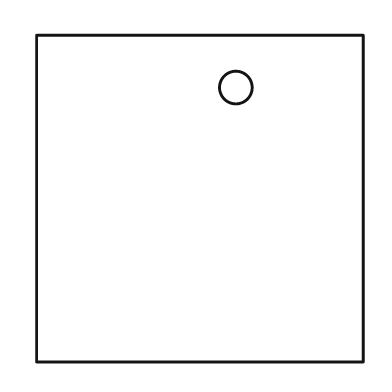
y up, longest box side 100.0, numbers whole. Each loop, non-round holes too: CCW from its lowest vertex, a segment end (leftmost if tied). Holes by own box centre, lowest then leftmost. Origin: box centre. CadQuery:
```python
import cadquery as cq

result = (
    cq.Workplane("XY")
    .moveTo(-50.0, -50.0)
    .lineTo(50.0, -50.0)
    .lineTo(50.0, 50.0)
    .lineTo(-50.0, 50.0)
    .close()
    .moveTo(11.0, 34.0)
    .circle(5.0)
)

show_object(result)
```